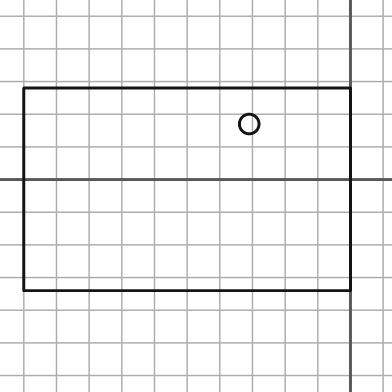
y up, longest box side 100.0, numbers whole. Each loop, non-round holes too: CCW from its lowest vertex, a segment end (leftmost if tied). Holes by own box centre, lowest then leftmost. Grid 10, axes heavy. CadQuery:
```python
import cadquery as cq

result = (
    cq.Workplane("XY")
    .moveTo(-100.0, -34.0)
    .lineTo(0.0, -34.0)
    .lineTo(0.0, 28.0)
    .lineTo(-100.0, 28.0)
    .close()
    .moveTo(-31.0, 17.0)
    .circle(3.0)
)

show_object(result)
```